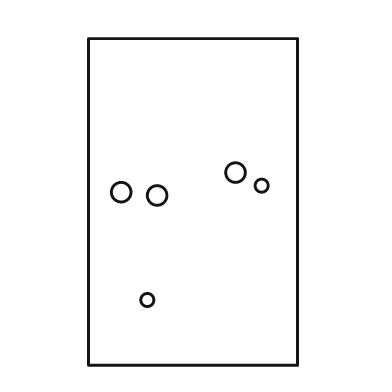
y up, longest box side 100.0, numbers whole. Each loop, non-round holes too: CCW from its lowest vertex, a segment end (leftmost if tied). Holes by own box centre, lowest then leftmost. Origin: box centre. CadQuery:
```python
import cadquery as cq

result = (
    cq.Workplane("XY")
    .moveTo(-32.0, -50.0)
    .lineTo(32.0, -50.0)
    .lineTo(32.0, 50.0)
    .lineTo(-32.0, 50.0)
    .close()
    .moveTo(-14.0, -30.0)
    .circle(2.0)
    .moveTo(-11.0, 2.0)
    .circle(3.0)
    .moveTo(-22.0, 3.0)
    .circle(3.0)
    .moveTo(21.0, 5.0)
    .circle(2.0)
    .moveTo(13.0, 9.0)
    .circle(3.0)
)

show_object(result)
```